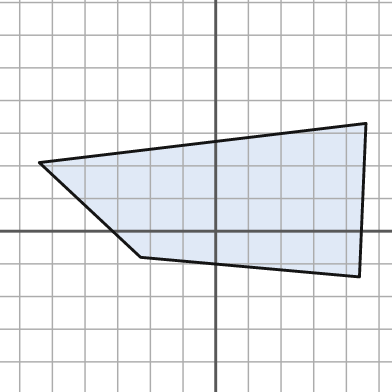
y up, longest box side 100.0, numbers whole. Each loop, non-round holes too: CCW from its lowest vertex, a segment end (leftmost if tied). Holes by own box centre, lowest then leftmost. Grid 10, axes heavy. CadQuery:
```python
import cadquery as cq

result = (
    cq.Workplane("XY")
    .moveTo(44.0, -14.0)
    .lineTo(46.0, 33.0)
    .lineTo(-54.0, 21.0)
    .lineTo(-23.0, -8.0)
    .close()
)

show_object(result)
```